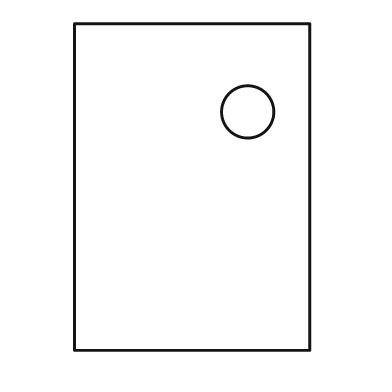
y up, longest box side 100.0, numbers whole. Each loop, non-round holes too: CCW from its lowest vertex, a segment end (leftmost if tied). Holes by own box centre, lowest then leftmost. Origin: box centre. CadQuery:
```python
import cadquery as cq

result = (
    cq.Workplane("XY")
    .moveTo(-36.0, -50.0)
    .lineTo(36.0, -50.0)
    .lineTo(36.0, 50.0)
    .lineTo(-36.0, 50.0)
    .close()
    .moveTo(17.0, 23.0)
    .circle(8.0)
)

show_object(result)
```